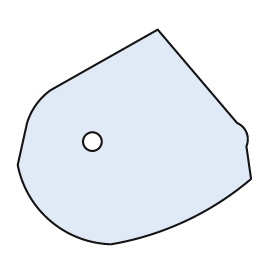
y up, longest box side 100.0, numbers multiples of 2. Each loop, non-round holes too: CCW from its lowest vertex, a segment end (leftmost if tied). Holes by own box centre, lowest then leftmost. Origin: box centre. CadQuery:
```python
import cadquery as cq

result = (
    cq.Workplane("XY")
    .moveTo(-10.0, -46.0)
    .threePointArc((22.0, -36.0), (50.0, -18.0))
    .lineTo(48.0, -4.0)
    .threePointArc((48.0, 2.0), (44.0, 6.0))
    .lineTo(10.0, 46.0)
    .lineTo(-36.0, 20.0)
    .threePointArc((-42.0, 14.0), (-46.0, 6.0))
    .lineTo(-50.0, -12.0)
    .threePointArc((-36.0, -36.0), (-10.0, -46.0))
    .close()
    .moveTo(-18.0, -2.0)
    .circle(4.0)
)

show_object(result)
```